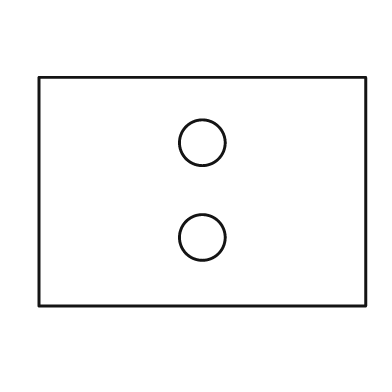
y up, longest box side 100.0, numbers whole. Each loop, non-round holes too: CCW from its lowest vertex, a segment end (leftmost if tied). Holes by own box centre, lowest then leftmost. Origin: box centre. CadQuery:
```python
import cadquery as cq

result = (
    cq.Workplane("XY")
    .moveTo(-50.0, -35.0)
    .lineTo(50.0, -35.0)
    .lineTo(50.0, 35.0)
    .lineTo(-50.0, 35.0)
    .close()
    .moveTo(0.0, -14.0)
    .circle(7.0)
    .moveTo(0.0, 15.0)
    .circle(7.0)
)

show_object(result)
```